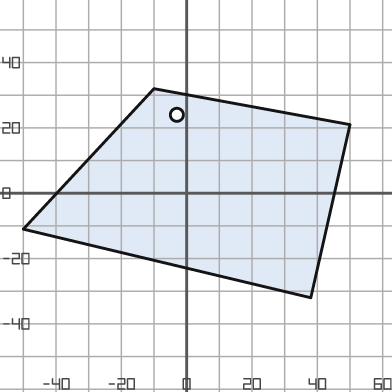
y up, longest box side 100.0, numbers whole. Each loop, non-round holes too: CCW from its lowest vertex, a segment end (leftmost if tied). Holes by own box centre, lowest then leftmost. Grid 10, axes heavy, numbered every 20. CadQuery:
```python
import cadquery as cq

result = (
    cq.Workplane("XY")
    .moveTo(38.0, -32.0)
    .lineTo(50.0, 21.0)
    .lineTo(-10.0, 32.0)
    .lineTo(-50.0, -11.0)
    .close()
    .moveTo(-3.0, 24.0)
    .circle(2.0)
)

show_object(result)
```